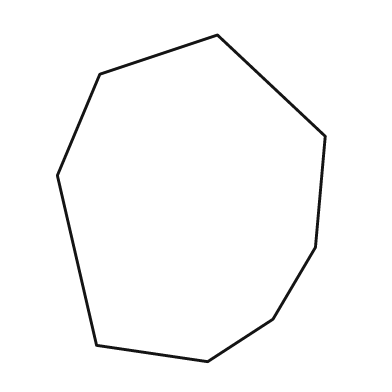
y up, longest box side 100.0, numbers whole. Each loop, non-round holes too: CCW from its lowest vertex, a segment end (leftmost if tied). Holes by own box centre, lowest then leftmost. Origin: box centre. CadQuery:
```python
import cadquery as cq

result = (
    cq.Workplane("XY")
    .moveTo(5.0, -50.0)
    .lineTo(25.0, -37.0)
    .lineTo(38.0, -15.0)
    .lineTo(41.0, 19.0)
    .lineTo(8.0, 50.0)
    .lineTo(-28.0, 38.0)
    .lineTo(-41.0, 7.0)
    .lineTo(-29.0, -45.0)
    .close()
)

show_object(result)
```